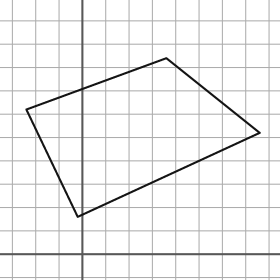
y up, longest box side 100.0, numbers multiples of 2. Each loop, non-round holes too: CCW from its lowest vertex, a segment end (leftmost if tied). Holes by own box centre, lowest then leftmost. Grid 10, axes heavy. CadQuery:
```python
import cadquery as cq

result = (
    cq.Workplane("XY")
    .moveTo(-2.0, 16.0)
    .lineTo(76.0, 52.0)
    .lineTo(36.0, 84.0)
    .lineTo(-24.0, 62.0)
    .close()
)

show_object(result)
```